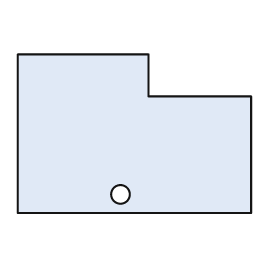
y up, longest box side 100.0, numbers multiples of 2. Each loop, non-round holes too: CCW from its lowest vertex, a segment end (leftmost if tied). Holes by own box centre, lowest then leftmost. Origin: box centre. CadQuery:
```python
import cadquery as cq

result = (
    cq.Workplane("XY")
    .moveTo(-50.0, -34.0)
    .lineTo(50.0, -34.0)
    .lineTo(50.0, 16.0)
    .lineTo(6.0, 16.0)
    .lineTo(6.0, 34.0)
    .lineTo(-50.0, 34.0)
    .close()
    .moveTo(-6.0, -26.0)
    .circle(4.0)
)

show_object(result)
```